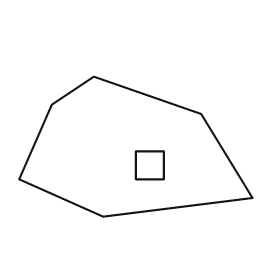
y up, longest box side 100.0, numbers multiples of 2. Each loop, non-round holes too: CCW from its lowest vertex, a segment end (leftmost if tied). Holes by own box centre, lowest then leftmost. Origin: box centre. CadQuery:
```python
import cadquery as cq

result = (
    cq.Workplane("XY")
    .moveTo(-14.0, -30.0)
    .lineTo(50.0, -22.0)
    .lineTo(28.0, 14.0)
    .lineTo(-18.0, 30.0)
    .lineTo(-36.0, 18.0)
    .lineTo(-50.0, -14.0)
    .close()
    .moveTo(0.0, -14.0)
    .lineTo(12.0, -14.0)
    .lineTo(12.0, -2.0)
    .lineTo(0.0, -2.0)
    .close()
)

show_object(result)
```